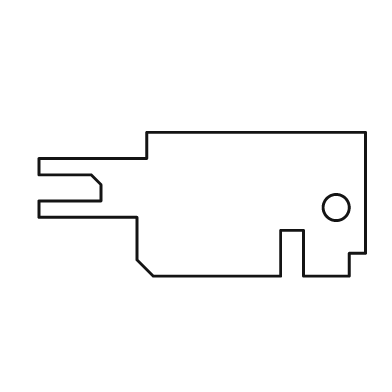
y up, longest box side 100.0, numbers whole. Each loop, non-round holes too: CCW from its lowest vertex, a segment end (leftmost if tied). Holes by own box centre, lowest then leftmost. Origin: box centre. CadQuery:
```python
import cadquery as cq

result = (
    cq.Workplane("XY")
    .moveTo(-15.0, -22.0)
    .lineTo(24.0, -22.0)
    .lineTo(24.0, -8.0)
    .lineTo(31.0, -8.0)
    .lineTo(31.0, -22.0)
    .lineTo(45.0, -22.0)
    .lineTo(45.0, -15.0)
    .lineTo(50.0, -15.0)
    .lineTo(50.0, 22.0)
    .lineTo(-17.0, 22.0)
    .lineTo(-17.0, 14.0)
    .lineTo(-50.0, 14.0)
    .lineTo(-50.0, 9.0)
    .lineTo(-34.0, 9.0)
    .lineTo(-31.0, 6.0)
    .lineTo(-31.0, 1.0)
    .lineTo(-50.0, 1.0)
    .lineTo(-50.0, -4.0)
    .lineTo(-20.0, -4.0)
    .lineTo(-20.0, -17.0)
    .close()
    .moveTo(41.0, -1.0)
    .circle(4.0)
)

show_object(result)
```